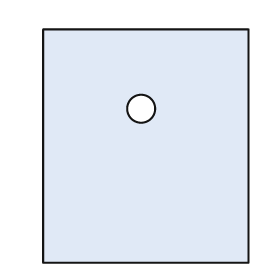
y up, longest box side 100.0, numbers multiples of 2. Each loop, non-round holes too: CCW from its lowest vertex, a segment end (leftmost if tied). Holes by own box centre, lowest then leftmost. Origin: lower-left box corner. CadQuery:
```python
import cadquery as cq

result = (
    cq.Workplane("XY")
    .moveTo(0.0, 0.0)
    .lineTo(88.0, 0.0)
    .lineTo(88.0, 100.0)
    .lineTo(0.0, 100.0)
    .close()
    .moveTo(42.0, 66.0)
    .circle(6.0)
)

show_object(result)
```